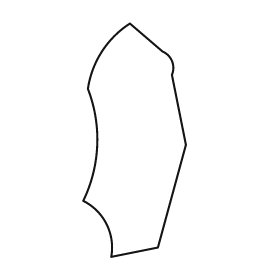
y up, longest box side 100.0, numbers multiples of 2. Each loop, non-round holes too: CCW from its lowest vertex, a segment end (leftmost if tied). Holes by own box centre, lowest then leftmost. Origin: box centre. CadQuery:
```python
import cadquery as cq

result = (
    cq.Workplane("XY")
    .moveTo(-10.0, -50.0)
    .lineTo(10.0, -46.0)
    .lineTo(22.0, -2.0)
    .lineTo(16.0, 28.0)
    .threePointArc((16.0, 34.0), (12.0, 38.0))
    .lineTo(-2.0, 50.0)
    .threePointArc((-14.0, 38.0), (-20.0, 22.0))
    .threePointArc((-16.0, -2.0), (-22.0, -26.0))
    .threePointArc((-12.0, -36.0), (-10.0, -50.0))
    .close()
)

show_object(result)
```